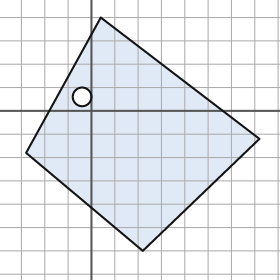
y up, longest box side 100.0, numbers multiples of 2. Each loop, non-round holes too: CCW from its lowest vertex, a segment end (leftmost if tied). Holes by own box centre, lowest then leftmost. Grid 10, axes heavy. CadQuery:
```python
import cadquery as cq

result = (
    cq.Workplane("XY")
    .moveTo(22.0, -60.0)
    .lineTo(72.0, -12.0)
    .lineTo(4.0, 40.0)
    .lineTo(-28.0, -18.0)
    .close()
    .moveTo(-4.0, 6.0)
    .circle(4.0)
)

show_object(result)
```